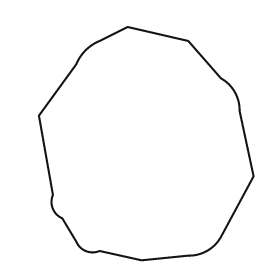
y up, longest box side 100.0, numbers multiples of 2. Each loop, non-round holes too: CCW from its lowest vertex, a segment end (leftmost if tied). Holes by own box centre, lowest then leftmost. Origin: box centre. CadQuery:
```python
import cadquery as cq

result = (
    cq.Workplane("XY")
    .moveTo(-2.0, -50.0)
    .lineTo(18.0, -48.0)
    .threePointArc((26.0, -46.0), (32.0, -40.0))
    .lineTo(46.0, -14.0)
    .lineTo(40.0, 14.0)
    .threePointArc((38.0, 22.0), (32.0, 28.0))
    .lineTo(18.0, 44.0)
    .lineTo(-8.0, 50.0)
    .lineTo(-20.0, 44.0)
    .threePointArc((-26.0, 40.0), (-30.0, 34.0))
    .lineTo(-46.0, 12.0)
    .lineTo(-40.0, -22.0)
    .threePointArc((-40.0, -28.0), (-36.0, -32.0))
    .lineTo(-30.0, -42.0)
    .threePointArc((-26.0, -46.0), (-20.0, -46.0))
    .close()
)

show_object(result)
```